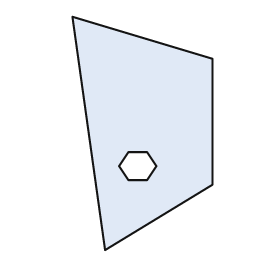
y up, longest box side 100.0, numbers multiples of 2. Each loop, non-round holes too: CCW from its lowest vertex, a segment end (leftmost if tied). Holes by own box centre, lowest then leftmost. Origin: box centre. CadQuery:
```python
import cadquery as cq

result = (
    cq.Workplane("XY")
    .moveTo(-16.0, -50.0)
    .lineTo(30.0, -22.0)
    .lineTo(30.0, 32.0)
    .lineTo(-30.0, 50.0)
    .close()
    .moveTo(-6.0, -20.0)
    .lineTo(2.0, -20.0)
    .lineTo(6.0, -14.0)
    .lineTo(2.0, -8.0)
    .lineTo(-6.0, -8.0)
    .lineTo(-10.0, -14.0)
    .close()
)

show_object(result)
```